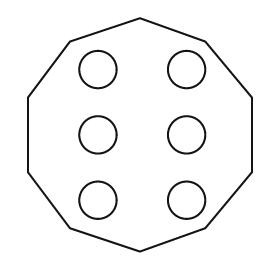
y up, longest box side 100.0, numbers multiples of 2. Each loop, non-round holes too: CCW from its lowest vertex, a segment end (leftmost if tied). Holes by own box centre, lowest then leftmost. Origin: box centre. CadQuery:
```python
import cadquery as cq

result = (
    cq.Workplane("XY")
    .moveTo(0.0, -50.0)
    .lineTo(28.0, -40.0)
    .lineTo(48.0, -16.0)
    .lineTo(48.0, 16.0)
    .lineTo(28.0, 40.0)
    .lineTo(0.0, 50.0)
    .lineTo(-30.0, 40.0)
    .lineTo(-48.0, 16.0)
    .lineTo(-48.0, -16.0)
    .lineTo(-30.0, -40.0)
    .close()
    .moveTo(-18.0, -28.0)
    .circle(8.0)
    .moveTo(20.0, -28.0)
    .circle(8.0)
    .moveTo(-18.0, 0.0)
    .circle(8.0)
    .moveTo(20.0, 0.0)
    .circle(8.0)
    .moveTo(-18.0, 28.0)
    .circle(8.0)
    .moveTo(20.0, 28.0)
    .circle(8.0)
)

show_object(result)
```